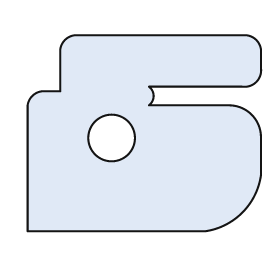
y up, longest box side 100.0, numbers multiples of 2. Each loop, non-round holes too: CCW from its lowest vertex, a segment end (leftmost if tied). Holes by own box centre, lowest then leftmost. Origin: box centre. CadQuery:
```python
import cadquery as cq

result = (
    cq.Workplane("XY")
    .moveTo(-50.0, -42.0)
    .lineTo(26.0, -42.0)
    .threePointArc((42.0, -34.0), (50.0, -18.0))
    .lineTo(50.0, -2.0)
    .threePointArc((46.0, 8.0), (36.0, 12.0))
    .lineTo(2.0, 12.0)
    .threePointArc((4.0, 16.0), (2.0, 20.0))
    .lineTo(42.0, 20.0)
    .threePointArc((48.0, 22.0), (50.0, 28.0))
    .lineTo(50.0, 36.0)
    .threePointArc((48.0, 40.0), (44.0, 42.0))
    .lineTo(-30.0, 42.0)
    .threePointArc((-34.0, 40.0), (-36.0, 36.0))
    .lineTo(-36.0, 18.0)
    .lineTo(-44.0, 18.0)
    .threePointArc((-48.0, 16.0), (-50.0, 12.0))
    .close()
    .moveTo(-14.0, -2.0)
    .circle(10.0)
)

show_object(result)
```